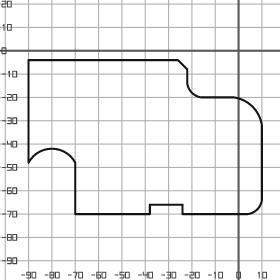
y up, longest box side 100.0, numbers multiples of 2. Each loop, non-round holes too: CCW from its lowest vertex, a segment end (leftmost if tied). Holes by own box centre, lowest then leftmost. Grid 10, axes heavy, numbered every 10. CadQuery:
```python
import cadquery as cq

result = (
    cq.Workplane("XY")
    .moveTo(-70.0, -70.0)
    .lineTo(-38.0, -70.0)
    .lineTo(-38.0, -66.0)
    .lineTo(-24.0, -66.0)
    .lineTo(-24.0, -70.0)
    .lineTo(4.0, -70.0)
    .threePointArc((8.0, -68.0), (10.0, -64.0))
    .lineTo(10.0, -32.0)
    .threePointArc((6.0, -24.0), (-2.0, -20.0))
    .lineTo(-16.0, -20.0)
    .threePointArc((-20.0, -18.0), (-22.0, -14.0))
    .lineTo(-22.0, -8.0)
    .lineTo(-26.0, -4.0)
    .lineTo(-90.0, -4.0)
    .lineTo(-90.0, -48.0)
    .threePointArc((-80.0, -42.0), (-70.0, -48.0))
    .close()
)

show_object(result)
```